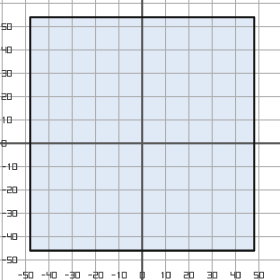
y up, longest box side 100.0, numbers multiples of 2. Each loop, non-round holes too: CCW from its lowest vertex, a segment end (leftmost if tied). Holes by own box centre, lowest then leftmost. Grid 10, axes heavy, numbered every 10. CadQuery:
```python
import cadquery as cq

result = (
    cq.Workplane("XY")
    .moveTo(-48.0, -46.0)
    .lineTo(48.0, -46.0)
    .lineTo(48.0, 54.0)
    .lineTo(-48.0, 54.0)
    .close()
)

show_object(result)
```